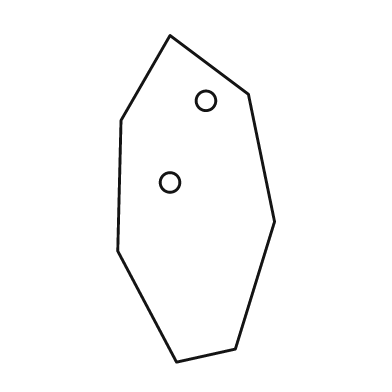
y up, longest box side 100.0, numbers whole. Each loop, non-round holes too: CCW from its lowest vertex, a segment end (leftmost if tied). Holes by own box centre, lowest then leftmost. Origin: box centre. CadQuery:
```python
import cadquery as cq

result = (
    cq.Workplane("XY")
    .moveTo(-6.0, -50.0)
    .lineTo(12.0, -46.0)
    .lineTo(24.0, -7.0)
    .lineTo(16.0, 32.0)
    .lineTo(-8.0, 50.0)
    .lineTo(-23.0, 24.0)
    .lineTo(-24.0, -16.0)
    .close()
    .moveTo(-8.0, 5.0)
    .circle(3.0)
    .moveTo(3.0, 30.0)
    .circle(3.0)
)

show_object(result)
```